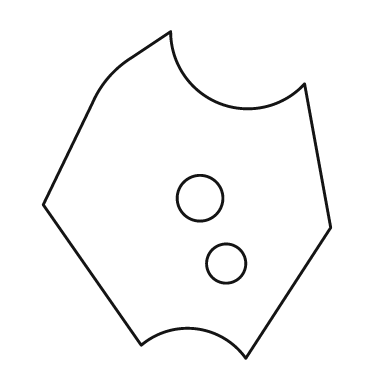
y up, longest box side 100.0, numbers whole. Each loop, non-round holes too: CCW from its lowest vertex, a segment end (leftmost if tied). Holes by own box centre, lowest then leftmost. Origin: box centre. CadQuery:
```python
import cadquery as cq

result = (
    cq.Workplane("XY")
    .moveTo(18.0, -50.0)
    .lineTo(44.0, -10.0)
    .lineTo(36.0, 34.0)
    .threePointArc((10.0, 28.0), (-5.0, 50.0))
    .lineTo(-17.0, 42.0)
    .threePointArc((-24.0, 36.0), (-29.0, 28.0))
    .lineTo(-44.0, -3.0)
    .lineTo(-14.0, -46.0)
    .threePointArc((3.0, -41.0), (18.0, -50.0))
    .close()
    .moveTo(12.0, -21.0)
    .circle(6.0)
    .moveTo(4.0, -1.0)
    .circle(7.0)
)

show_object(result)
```